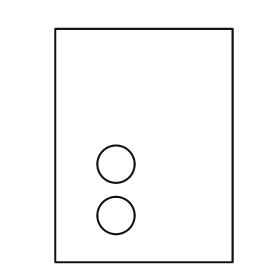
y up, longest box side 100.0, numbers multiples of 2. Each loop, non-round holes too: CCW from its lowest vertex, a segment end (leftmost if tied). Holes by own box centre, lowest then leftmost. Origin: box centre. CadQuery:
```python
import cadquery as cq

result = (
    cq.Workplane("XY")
    .moveTo(-38.0, -50.0)
    .lineTo(38.0, -50.0)
    .lineTo(38.0, 50.0)
    .lineTo(-38.0, 50.0)
    .close()
    .moveTo(-12.0, -30.0)
    .circle(8.0)
    .moveTo(-12.0, -8.0)
    .circle(8.0)
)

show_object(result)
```